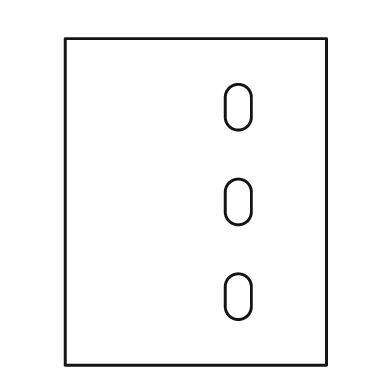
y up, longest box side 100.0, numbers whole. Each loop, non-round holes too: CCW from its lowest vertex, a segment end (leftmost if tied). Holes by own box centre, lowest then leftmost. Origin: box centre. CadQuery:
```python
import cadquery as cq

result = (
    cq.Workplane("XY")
    .moveTo(-40.0, -50.0)
    .lineTo(40.0, -50.0)
    .lineTo(40.0, 50.0)
    .lineTo(-40.0, 50.0)
    .close()
    .moveTo(9.0, -32.0)
    .threePointArc((13.0, -36.0), (17.0, -32.0))
    .lineTo(17.0, -26.0)
    .threePointArc((13.0, -22.0), (9.0, -26.0))
    .close()
    .moveTo(9.0, -3.0)
    .threePointArc((13.0, -7.0), (17.0, -3.0))
    .lineTo(17.0, 3.0)
    .threePointArc((13.0, 7.0), (9.0, 3.0))
    .close()
    .moveTo(9.0, 26.0)
    .threePointArc((13.0, 22.0), (17.0, 26.0))
    .lineTo(17.0, 32.0)
    .threePointArc((13.0, 36.0), (9.0, 32.0))
    .close()
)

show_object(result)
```